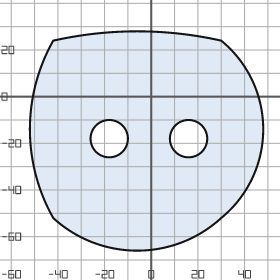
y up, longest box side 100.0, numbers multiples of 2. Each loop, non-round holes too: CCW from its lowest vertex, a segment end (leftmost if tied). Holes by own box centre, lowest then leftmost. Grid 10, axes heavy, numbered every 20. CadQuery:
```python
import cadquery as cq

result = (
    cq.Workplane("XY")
    .moveTo(-42.0, -52.0)
    .threePointArc((-6.0, -66.0), (30.0, -52.0))
    .threePointArc((48.0, -14.0), (30.0, 24.0))
    .threePointArc((-6.0, 28.0), (-42.0, 24.0))
    .threePointArc((-52.0, -14.0), (-42.0, -52.0))
    .close()
    .moveTo(-18.0, -18.0)
    .circle(8.0)
    .moveTo(16.0, -18.0)
    .circle(8.0)
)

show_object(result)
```